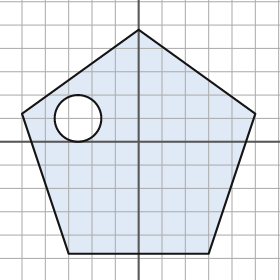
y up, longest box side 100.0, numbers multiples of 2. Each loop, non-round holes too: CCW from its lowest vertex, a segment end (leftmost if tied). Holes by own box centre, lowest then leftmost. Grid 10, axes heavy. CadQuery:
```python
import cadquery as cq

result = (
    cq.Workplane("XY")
    .moveTo(-30.0, -48.0)
    .lineTo(30.0, -48.0)
    .lineTo(50.0, 12.0)
    .lineTo(0.0, 48.0)
    .lineTo(-50.0, 12.0)
    .close()
    .moveTo(-26.0, 10.0)
    .circle(10.0)
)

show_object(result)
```